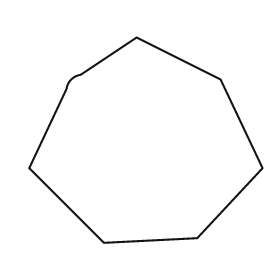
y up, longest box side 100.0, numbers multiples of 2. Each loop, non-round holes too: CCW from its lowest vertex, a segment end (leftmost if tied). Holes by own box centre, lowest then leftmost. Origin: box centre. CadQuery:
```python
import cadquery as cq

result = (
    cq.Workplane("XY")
    .moveTo(-18.0, -44.0)
    .lineTo(22.0, -42.0)
    .lineTo(50.0, -12.0)
    .lineTo(32.0, 26.0)
    .lineTo(-4.0, 44.0)
    .lineTo(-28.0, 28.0)
    .threePointArc((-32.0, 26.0), (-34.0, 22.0))
    .lineTo(-50.0, -12.0)
    .close()
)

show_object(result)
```